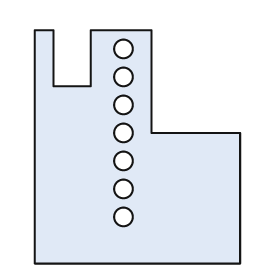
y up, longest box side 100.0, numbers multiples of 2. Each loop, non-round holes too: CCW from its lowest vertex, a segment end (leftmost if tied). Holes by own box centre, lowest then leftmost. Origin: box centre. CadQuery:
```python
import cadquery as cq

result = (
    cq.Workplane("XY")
    .moveTo(-44.0, -50.0)
    .lineTo(44.0, -50.0)
    .lineTo(44.0, 6.0)
    .lineTo(6.0, 6.0)
    .lineTo(6.0, 50.0)
    .lineTo(-20.0, 50.0)
    .lineTo(-20.0, 26.0)
    .lineTo(-36.0, 26.0)
    .lineTo(-36.0, 50.0)
    .lineTo(-44.0, 50.0)
    .close()
    .moveTo(-6.0, -30.0)
    .circle(4.0)
    .moveTo(-6.0, -18.0)
    .circle(4.0)
    .moveTo(-6.0, -6.0)
    .circle(4.0)
    .moveTo(-6.0, 6.0)
    .circle(4.0)
    .moveTo(-6.0, 18.0)
    .circle(4.0)
    .moveTo(-6.0, 30.0)
    .circle(4.0)
    .moveTo(-6.0, 42.0)
    .circle(4.0)
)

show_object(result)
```